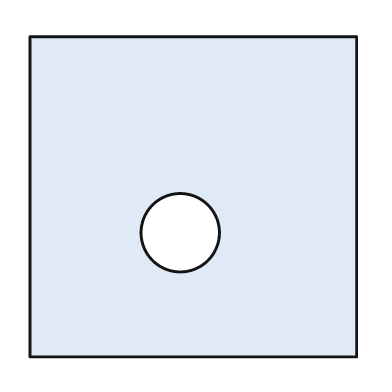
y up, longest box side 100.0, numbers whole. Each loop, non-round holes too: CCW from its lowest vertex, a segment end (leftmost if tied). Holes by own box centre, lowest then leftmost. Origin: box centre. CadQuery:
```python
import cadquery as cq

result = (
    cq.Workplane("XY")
    .moveTo(-50.0, -49.0)
    .lineTo(50.0, -49.0)
    .lineTo(50.0, 49.0)
    .lineTo(-50.0, 49.0)
    .close()
    .moveTo(-4.0, -11.0)
    .circle(12.0)
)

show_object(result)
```